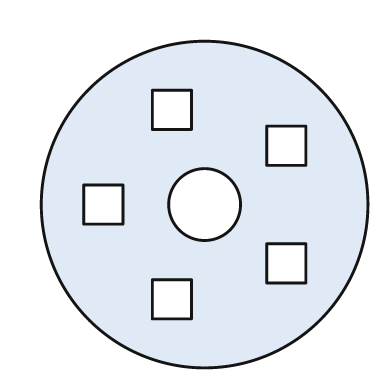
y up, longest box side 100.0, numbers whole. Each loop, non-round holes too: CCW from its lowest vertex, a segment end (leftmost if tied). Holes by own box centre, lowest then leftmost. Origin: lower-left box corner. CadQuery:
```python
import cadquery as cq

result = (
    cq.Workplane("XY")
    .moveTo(50.0, 50.0)
    .circle(50.0)
    .moveTo(34.0, 15.0)
    .lineTo(46.0, 15.0)
    .lineTo(46.0, 27.0)
    .lineTo(34.0, 27.0)
    .close()
    .moveTo(69.0, 26.0)
    .lineTo(81.0, 26.0)
    .lineTo(81.0, 38.0)
    .lineTo(69.0, 38.0)
    .close()
    .moveTo(13.0, 44.0)
    .lineTo(25.0, 44.0)
    .lineTo(25.0, 56.0)
    .lineTo(13.0, 56.0)
    .close()
    .moveTo(50.0, 50.0)
    .circle(11.0)
    .moveTo(69.0, 62.0)
    .lineTo(81.0, 62.0)
    .lineTo(81.0, 74.0)
    .lineTo(69.0, 74.0)
    .close()
    .moveTo(34.0, 73.0)
    .lineTo(46.0, 73.0)
    .lineTo(46.0, 85.0)
    .lineTo(34.0, 85.0)
    .close()
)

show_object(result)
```